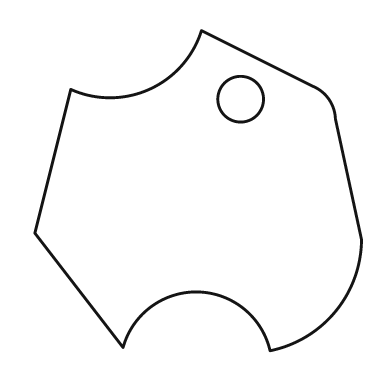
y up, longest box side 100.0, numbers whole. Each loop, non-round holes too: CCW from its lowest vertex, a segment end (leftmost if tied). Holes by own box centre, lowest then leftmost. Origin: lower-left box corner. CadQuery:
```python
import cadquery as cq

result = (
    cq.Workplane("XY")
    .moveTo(72.0, 0.0)
    .threePointArc((92.0, 12.0), (100.0, 34.0))
    .lineTo(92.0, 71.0)
    .threePointArc((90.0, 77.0), (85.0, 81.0))
    .lineTo(51.0, 98.0)
    .threePointArc((35.0, 80.0), (11.0, 80.0))
    .lineTo(0.0, 36.0)
    .lineTo(27.0, 1.0)
    .threePointArc((50.0, 18.0), (72.0, 0.0))
    .close()
    .moveTo(63.0, 77.0)
    .circle(7.0)
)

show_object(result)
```